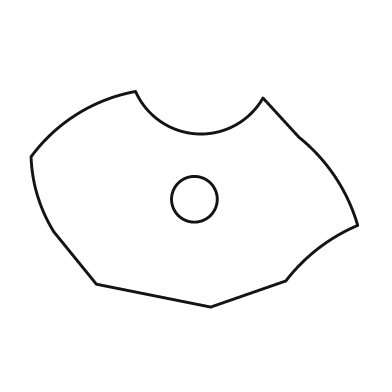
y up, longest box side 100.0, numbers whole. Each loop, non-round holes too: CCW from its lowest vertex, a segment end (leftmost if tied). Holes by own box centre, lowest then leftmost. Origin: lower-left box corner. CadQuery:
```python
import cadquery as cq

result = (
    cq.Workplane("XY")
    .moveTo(55.0, 0.0)
    .lineTo(78.0, 8.0)
    .threePointArc((88.0, 18.0), (100.0, 25.0))
    .threePointArc((93.0, 40.0), (82.0, 52.0))
    .lineTo(71.0, 64.0)
    .threePointArc((51.0, 53.0), (32.0, 66.0))
    .threePointArc((14.0, 59.0), (0.0, 46.0))
    .threePointArc((2.0, 34.0), (7.0, 23.0))
    .lineTo(20.0, 7.0)
    .close()
    .moveTo(50.0, 33.0)
    .circle(7.0)
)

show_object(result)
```